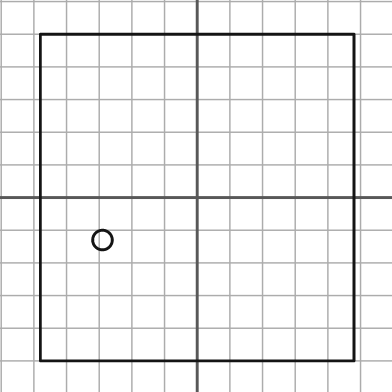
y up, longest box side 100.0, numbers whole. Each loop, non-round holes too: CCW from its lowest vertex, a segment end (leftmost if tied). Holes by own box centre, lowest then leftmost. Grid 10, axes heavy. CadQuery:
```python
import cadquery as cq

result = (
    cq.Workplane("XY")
    .moveTo(-48.0, -50.0)
    .lineTo(48.0, -50.0)
    .lineTo(48.0, 50.0)
    .lineTo(-48.0, 50.0)
    .close()
    .moveTo(-29.0, -13.0)
    .circle(3.0)
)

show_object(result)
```